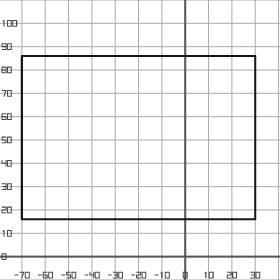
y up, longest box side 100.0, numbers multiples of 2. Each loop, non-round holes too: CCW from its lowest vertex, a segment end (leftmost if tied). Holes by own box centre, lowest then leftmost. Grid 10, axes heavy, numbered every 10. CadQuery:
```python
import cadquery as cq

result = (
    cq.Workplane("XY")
    .moveTo(-70.0, 16.0)
    .lineTo(30.0, 16.0)
    .lineTo(30.0, 86.0)
    .lineTo(-70.0, 86.0)
    .close()
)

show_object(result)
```